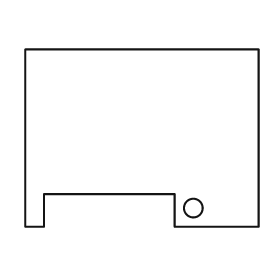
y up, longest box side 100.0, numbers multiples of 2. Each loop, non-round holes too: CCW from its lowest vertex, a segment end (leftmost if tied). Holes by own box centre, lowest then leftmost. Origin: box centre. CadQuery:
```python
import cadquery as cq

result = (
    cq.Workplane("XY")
    .moveTo(-50.0, -38.0)
    .lineTo(-42.0, -38.0)
    .lineTo(-42.0, -24.0)
    .lineTo(14.0, -24.0)
    .lineTo(14.0, -38.0)
    .lineTo(50.0, -38.0)
    .lineTo(50.0, 38.0)
    .lineTo(-50.0, 38.0)
    .close()
    .moveTo(22.0, -30.0)
    .circle(4.0)
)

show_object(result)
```